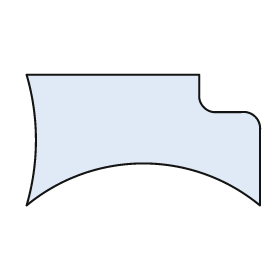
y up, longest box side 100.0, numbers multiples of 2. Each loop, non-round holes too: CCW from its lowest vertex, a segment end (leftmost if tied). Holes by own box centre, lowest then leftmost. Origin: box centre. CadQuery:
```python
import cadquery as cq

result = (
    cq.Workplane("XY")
    .moveTo(-50.0, -28.0)
    .threePointArc((0.0, -10.0), (50.0, -28.0))
    .lineTo(50.0, 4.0)
    .threePointArc((48.0, 10.0), (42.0, 12.0))
    .lineTo(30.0, 12.0)
    .threePointArc((26.0, 14.0), (24.0, 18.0))
    .lineTo(24.0, 28.0)
    .lineTo(-50.0, 28.0)
    .threePointArc((-46.0, 0.0), (-50.0, -28.0))
    .close()
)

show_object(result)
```